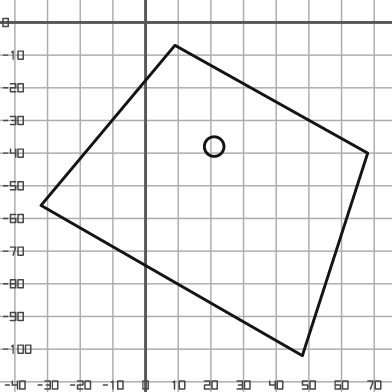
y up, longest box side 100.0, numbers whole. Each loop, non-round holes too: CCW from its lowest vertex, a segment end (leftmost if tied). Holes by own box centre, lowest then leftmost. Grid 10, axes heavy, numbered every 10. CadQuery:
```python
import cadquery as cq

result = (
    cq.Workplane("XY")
    .moveTo(48.0, -102.0)
    .lineTo(68.0, -40.0)
    .lineTo(9.0, -7.0)
    .lineTo(-32.0, -56.0)
    .close()
    .moveTo(21.0, -38.0)
    .circle(3.0)
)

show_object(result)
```